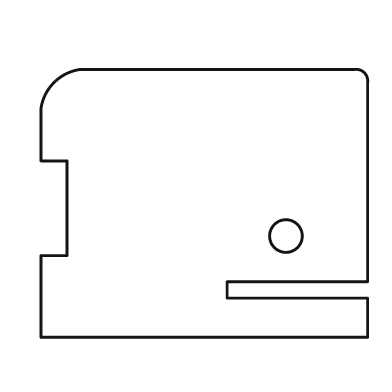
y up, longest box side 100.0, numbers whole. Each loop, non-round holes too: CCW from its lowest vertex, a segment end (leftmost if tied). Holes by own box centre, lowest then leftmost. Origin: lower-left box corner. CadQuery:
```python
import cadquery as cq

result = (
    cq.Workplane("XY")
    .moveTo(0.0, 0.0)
    .lineTo(100.0, 0.0)
    .lineTo(100.0, 12.0)
    .lineTo(57.0, 12.0)
    .lineTo(57.0, 17.0)
    .lineTo(100.0, 17.0)
    .lineTo(100.0, 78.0)
    .threePointArc((99.0, 81.0), (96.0, 82.0))
    .lineTo(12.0, 82.0)
    .threePointArc((4.0, 78.0), (0.0, 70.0))
    .lineTo(0.0, 54.0)
    .lineTo(8.0, 54.0)
    .lineTo(8.0, 25.0)
    .lineTo(0.0, 25.0)
    .close()
    .moveTo(75.0, 31.0)
    .circle(5.0)
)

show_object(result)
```